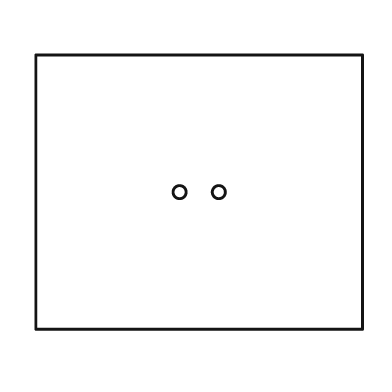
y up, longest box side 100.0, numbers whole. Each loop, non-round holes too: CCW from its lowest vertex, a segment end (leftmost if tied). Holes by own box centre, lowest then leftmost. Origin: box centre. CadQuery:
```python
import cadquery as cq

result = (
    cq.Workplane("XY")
    .moveTo(-50.0, -42.0)
    .lineTo(50.0, -42.0)
    .lineTo(50.0, 42.0)
    .lineTo(-50.0, 42.0)
    .close()
    .moveTo(-6.0, 0.0)
    .circle(2.0)
    .moveTo(6.0, 0.0)
    .circle(2.0)
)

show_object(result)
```